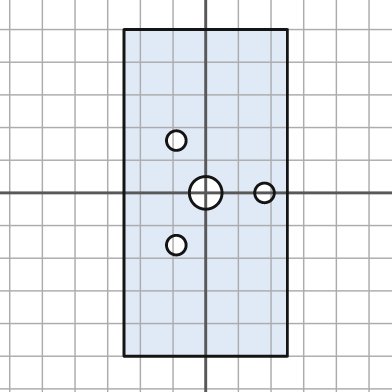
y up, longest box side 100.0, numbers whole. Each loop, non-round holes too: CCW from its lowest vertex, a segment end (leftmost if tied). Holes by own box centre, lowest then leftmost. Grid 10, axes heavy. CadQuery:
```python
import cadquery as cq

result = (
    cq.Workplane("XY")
    .moveTo(-25.0, -50.0)
    .lineTo(25.0, -50.0)
    .lineTo(25.0, 50.0)
    .lineTo(-25.0, 50.0)
    .close()
    .moveTo(-9.0, -16.0)
    .circle(3.0)
    .moveTo(0.0, 0.0)
    .circle(5.0)
    .moveTo(18.0, 0.0)
    .circle(3.0)
    .moveTo(-9.0, 16.0)
    .circle(3.0)
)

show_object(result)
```